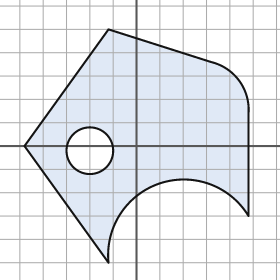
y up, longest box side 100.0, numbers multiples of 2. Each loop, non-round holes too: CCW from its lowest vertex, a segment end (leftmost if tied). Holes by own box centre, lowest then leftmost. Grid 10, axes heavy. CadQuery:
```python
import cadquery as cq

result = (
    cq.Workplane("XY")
    .moveTo(-12.0, -50.0)
    .threePointArc((10.0, -16.0), (48.0, -30.0))
    .lineTo(48.0, 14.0)
    .threePointArc((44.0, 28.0), (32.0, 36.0))
    .lineTo(-12.0, 50.0)
    .lineTo(-48.0, 0.0)
    .close()
    .moveTo(-20.0, -2.0)
    .circle(10.0)
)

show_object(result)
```